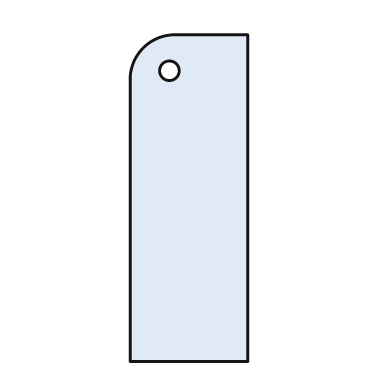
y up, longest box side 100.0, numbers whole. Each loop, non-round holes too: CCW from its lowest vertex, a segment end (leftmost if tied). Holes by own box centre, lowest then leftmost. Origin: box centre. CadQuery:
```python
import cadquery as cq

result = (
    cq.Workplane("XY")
    .moveTo(-18.0, -50.0)
    .lineTo(18.0, -50.0)
    .lineTo(18.0, 50.0)
    .lineTo(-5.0, 50.0)
    .threePointArc((-14.0, 46.0), (-18.0, 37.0))
    .close()
    .moveTo(-6.0, 39.0)
    .circle(3.0)
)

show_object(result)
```